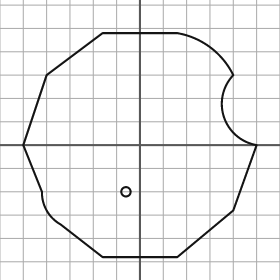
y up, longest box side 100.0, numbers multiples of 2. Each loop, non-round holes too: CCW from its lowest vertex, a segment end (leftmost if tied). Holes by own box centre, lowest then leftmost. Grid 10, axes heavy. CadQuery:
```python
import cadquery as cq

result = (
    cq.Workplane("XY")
    .moveTo(-16.0, -48.0)
    .lineTo(16.0, -48.0)
    .lineTo(40.0, -28.0)
    .lineTo(50.0, 0.0)
    .threePointArc((36.0, 12.0), (40.0, 30.0))
    .threePointArc((30.0, 42.0), (16.0, 48.0))
    .lineTo(-16.0, 48.0)
    .lineTo(-40.0, 30.0)
    .lineTo(-50.0, 0.0)
    .lineTo(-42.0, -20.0)
    .threePointArc((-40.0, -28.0), (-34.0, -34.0))
    .close()
    .moveTo(-6.0, -20.0)
    .circle(2.0)
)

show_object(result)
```